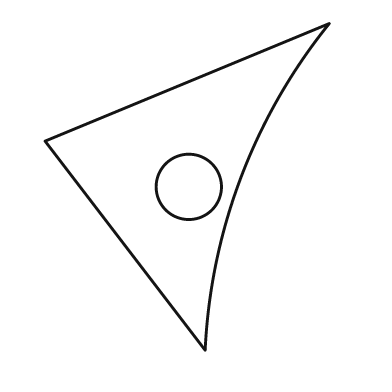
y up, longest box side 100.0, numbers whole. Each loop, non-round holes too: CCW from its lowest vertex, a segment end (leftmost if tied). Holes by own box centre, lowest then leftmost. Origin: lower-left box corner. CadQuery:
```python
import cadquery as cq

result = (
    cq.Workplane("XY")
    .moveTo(49.0, 0.0)
    .threePointArc((60.0, 53.0), (87.0, 100.0))
    .lineTo(0.0, 64.0)
    .close()
    .moveTo(44.0, 50.0)
    .circle(10.0)
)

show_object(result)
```